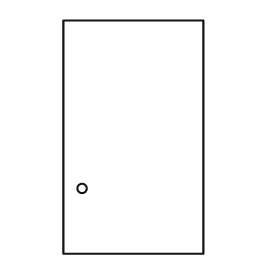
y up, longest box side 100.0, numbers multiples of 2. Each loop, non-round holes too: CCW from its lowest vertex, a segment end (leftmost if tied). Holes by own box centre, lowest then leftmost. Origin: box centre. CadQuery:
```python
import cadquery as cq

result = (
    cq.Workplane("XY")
    .moveTo(-30.0, -50.0)
    .lineTo(30.0, -50.0)
    .lineTo(30.0, 50.0)
    .lineTo(-30.0, 50.0)
    .close()
    .moveTo(-22.0, -22.0)
    .circle(2.0)
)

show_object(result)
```